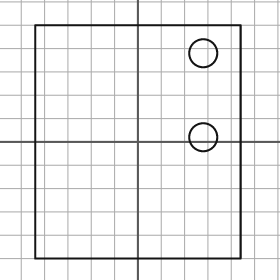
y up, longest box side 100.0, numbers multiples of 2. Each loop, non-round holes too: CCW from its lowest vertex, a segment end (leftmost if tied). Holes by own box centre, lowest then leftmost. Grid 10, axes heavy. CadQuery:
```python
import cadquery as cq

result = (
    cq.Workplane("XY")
    .moveTo(-44.0, -50.0)
    .lineTo(44.0, -50.0)
    .lineTo(44.0, 50.0)
    .lineTo(-44.0, 50.0)
    .close()
    .moveTo(28.0, 2.0)
    .circle(6.0)
    .moveTo(28.0, 38.0)
    .circle(6.0)
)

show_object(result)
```